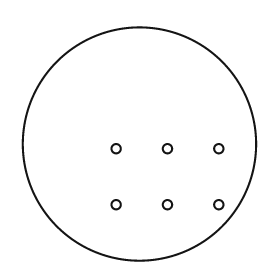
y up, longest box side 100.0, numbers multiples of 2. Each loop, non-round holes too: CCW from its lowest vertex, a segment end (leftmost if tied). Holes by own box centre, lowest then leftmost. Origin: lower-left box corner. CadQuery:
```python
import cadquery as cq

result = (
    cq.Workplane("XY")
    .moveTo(50.0, 50.0)
    .circle(50.0)
    .moveTo(40.0, 24.0)
    .circle(2.0)
    .moveTo(62.0, 24.0)
    .circle(2.0)
    .moveTo(84.0, 24.0)
    .circle(2.0)
    .moveTo(40.0, 48.0)
    .circle(2.0)
    .moveTo(62.0, 48.0)
    .circle(2.0)
    .moveTo(84.0, 48.0)
    .circle(2.0)
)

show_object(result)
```